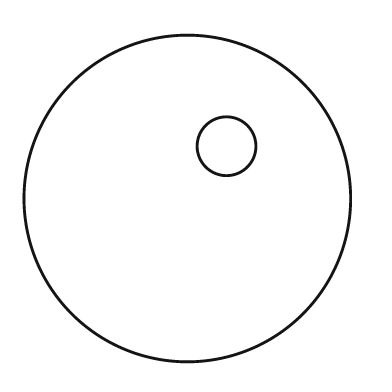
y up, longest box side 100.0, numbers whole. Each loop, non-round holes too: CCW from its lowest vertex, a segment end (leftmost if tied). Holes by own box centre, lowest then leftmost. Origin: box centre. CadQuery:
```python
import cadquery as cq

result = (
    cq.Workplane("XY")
    .moveTo(0.0, 0.0)
    .circle(50.0)
    .moveTo(12.0, 16.0)
    .circle(9.0)
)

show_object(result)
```